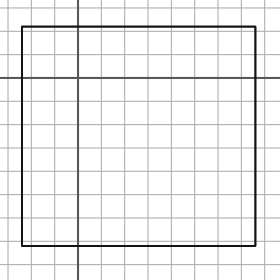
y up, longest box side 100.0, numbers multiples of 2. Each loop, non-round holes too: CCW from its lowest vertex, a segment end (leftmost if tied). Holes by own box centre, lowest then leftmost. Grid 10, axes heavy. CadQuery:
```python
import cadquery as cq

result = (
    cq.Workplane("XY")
    .moveTo(-24.0, -72.0)
    .lineTo(76.0, -72.0)
    .lineTo(76.0, 22.0)
    .lineTo(-24.0, 22.0)
    .close()
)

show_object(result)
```